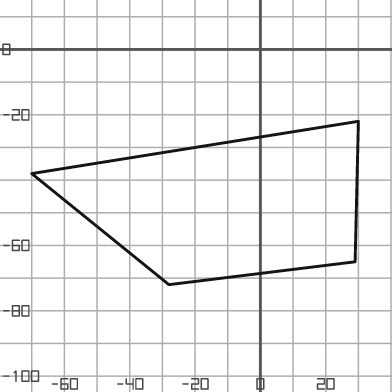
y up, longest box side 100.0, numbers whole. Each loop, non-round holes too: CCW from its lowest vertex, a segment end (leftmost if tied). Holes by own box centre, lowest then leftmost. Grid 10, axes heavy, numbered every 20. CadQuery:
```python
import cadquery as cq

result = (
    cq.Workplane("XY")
    .moveTo(-28.0, -72.0)
    .lineTo(29.0, -65.0)
    .lineTo(30.0, -22.0)
    .lineTo(-70.0, -38.0)
    .close()
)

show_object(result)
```